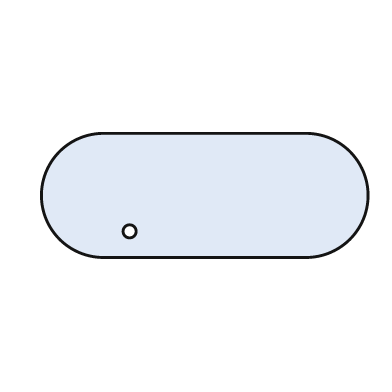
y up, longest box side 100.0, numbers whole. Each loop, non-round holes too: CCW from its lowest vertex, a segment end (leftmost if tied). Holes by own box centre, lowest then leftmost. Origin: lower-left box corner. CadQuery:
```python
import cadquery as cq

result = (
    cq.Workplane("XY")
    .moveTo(19.0, 0.0)
    .lineTo(81.0, 0.0)
    .threePointArc((100.0, 19.0), (81.0, 38.0))
    .lineTo(19.0, 38.0)
    .threePointArc((0.0, 19.0), (19.0, 0.0))
    .close()
    .moveTo(27.0, 8.0)
    .circle(2.0)
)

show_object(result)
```